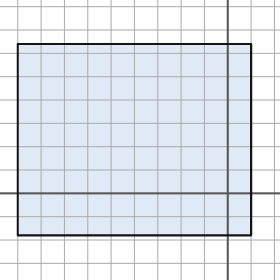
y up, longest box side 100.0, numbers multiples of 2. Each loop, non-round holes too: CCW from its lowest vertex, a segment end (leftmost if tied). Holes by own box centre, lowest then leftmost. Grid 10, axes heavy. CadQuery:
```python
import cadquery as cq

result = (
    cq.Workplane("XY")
    .moveTo(-90.0, -18.0)
    .lineTo(10.0, -18.0)
    .lineTo(10.0, 64.0)
    .lineTo(-90.0, 64.0)
    .close()
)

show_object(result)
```